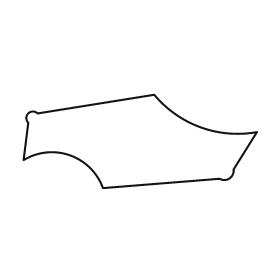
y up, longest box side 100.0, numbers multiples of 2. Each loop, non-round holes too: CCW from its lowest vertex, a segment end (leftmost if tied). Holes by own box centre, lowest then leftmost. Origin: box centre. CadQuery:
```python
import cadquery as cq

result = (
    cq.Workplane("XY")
    .moveTo(-16.0, -20.0)
    .lineTo(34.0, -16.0)
    .threePointArc((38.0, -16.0), (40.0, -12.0))
    .lineTo(50.0, 4.0)
    .threePointArc((26.0, 6.0), (6.0, 20.0))
    .lineTo(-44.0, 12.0)
    .threePointArc((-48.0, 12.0), (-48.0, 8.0))
    .lineTo(-50.0, -8.0)
    .threePointArc((-30.0, -6.0), (-16.0, -20.0))
    .close()
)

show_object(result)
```